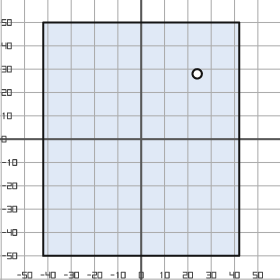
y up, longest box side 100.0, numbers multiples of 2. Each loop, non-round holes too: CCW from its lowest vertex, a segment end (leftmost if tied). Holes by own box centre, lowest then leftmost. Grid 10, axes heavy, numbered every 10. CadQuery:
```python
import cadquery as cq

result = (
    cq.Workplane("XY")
    .moveTo(-42.0, -50.0)
    .lineTo(42.0, -50.0)
    .lineTo(42.0, 50.0)
    .lineTo(-42.0, 50.0)
    .close()
    .moveTo(24.0, 28.0)
    .circle(2.0)
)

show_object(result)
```